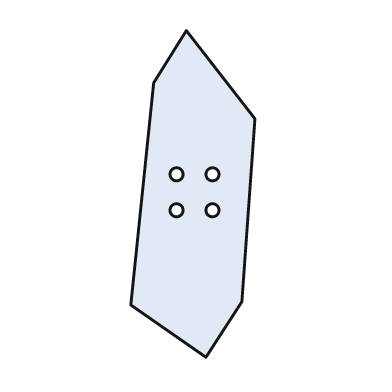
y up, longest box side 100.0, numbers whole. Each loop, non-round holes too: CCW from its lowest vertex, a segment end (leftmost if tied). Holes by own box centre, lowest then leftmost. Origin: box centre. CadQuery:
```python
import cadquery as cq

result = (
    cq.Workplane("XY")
    .moveTo(4.0, -50.0)
    .lineTo(15.0, -33.0)
    .lineTo(19.0, 23.0)
    .lineTo(-2.0, 50.0)
    .lineTo(-12.0, 34.0)
    .lineTo(-19.0, -34.0)
    .close()
    .moveTo(-5.0, -5.0)
    .circle(2.0)
    .moveTo(6.0, -5.0)
    .circle(2.0)
    .moveTo(-5.0, 6.0)
    .circle(2.0)
    .moveTo(6.0, 6.0)
    .circle(2.0)
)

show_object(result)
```